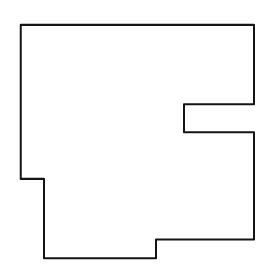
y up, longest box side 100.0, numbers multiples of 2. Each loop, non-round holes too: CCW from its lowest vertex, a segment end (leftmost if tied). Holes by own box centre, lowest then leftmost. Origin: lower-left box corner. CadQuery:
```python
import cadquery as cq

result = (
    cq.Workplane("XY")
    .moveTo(10.0, 0.0)
    .lineTo(58.0, 0.0)
    .lineTo(58.0, 8.0)
    .lineTo(100.0, 8.0)
    .lineTo(100.0, 54.0)
    .lineTo(70.0, 54.0)
    .lineTo(70.0, 66.0)
    .lineTo(100.0, 66.0)
    .lineTo(100.0, 100.0)
    .lineTo(0.0, 100.0)
    .lineTo(0.0, 34.0)
    .lineTo(10.0, 34.0)
    .close()
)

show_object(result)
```